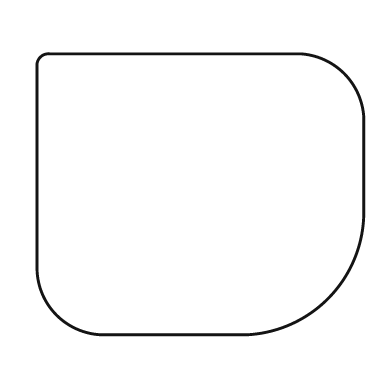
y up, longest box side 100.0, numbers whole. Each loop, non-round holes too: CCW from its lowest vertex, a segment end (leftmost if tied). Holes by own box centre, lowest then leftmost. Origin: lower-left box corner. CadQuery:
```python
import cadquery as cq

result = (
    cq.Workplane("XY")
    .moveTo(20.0, 0.0)
    .lineTo(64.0, 0.0)
    .threePointArc((89.0, 11.0), (100.0, 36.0))
    .lineTo(100.0, 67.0)
    .threePointArc((94.0, 80.0), (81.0, 86.0))
    .lineTo(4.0, 86.0)
    .threePointArc((1.0, 85.0), (0.0, 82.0))
    .lineTo(0.0, 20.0)
    .threePointArc((6.0, 6.0), (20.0, 0.0))
    .close()
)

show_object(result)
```